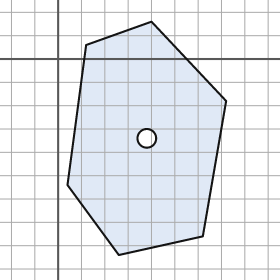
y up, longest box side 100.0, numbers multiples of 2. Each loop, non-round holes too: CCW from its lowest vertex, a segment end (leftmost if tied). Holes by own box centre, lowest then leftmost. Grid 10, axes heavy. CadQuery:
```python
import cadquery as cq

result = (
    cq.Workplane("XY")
    .moveTo(26.0, -84.0)
    .lineTo(62.0, -76.0)
    .lineTo(72.0, -18.0)
    .lineTo(40.0, 16.0)
    .lineTo(12.0, 6.0)
    .lineTo(4.0, -54.0)
    .close()
    .moveTo(38.0, -34.0)
    .circle(4.0)
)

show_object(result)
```